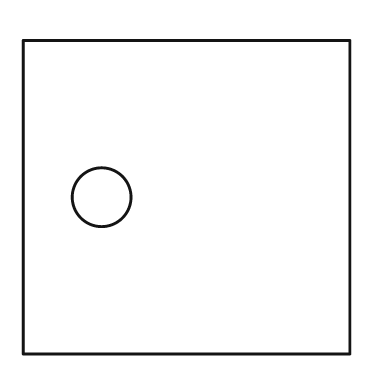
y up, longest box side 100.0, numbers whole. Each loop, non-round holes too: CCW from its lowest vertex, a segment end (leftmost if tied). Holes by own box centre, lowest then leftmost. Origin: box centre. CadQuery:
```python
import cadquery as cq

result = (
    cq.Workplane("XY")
    .moveTo(-50.0, -48.0)
    .lineTo(50.0, -48.0)
    .lineTo(50.0, 48.0)
    .lineTo(-50.0, 48.0)
    .close()
    .moveTo(-26.0, 0.0)
    .circle(9.0)
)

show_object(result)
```